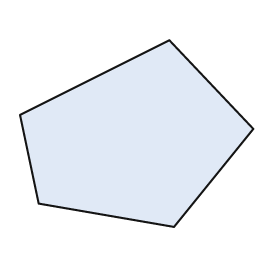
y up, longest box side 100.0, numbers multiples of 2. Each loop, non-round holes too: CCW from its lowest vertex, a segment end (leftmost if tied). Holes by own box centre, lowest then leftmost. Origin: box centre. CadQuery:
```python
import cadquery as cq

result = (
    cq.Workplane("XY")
    .moveTo(16.0, -40.0)
    .lineTo(50.0, 2.0)
    .lineTo(14.0, 40.0)
    .lineTo(-50.0, 8.0)
    .lineTo(-42.0, -30.0)
    .close()
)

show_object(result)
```